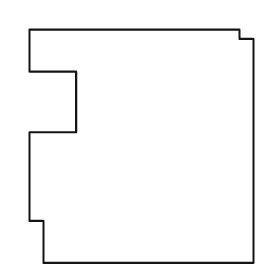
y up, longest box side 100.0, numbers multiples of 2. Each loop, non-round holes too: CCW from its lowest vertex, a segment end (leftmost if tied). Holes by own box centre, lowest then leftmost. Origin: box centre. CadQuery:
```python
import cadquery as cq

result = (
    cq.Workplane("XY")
    .moveTo(-42.0, -50.0)
    .lineTo(48.0, -50.0)
    .lineTo(48.0, 46.0)
    .lineTo(42.0, 46.0)
    .lineTo(42.0, 50.0)
    .lineTo(-48.0, 50.0)
    .lineTo(-48.0, 32.0)
    .lineTo(-28.0, 32.0)
    .lineTo(-28.0, 6.0)
    .lineTo(-48.0, 6.0)
    .lineTo(-48.0, -32.0)
    .lineTo(-42.0, -32.0)
    .close()
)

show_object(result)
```